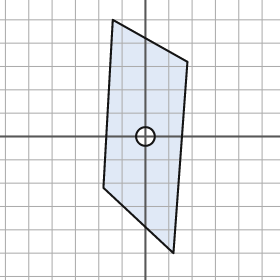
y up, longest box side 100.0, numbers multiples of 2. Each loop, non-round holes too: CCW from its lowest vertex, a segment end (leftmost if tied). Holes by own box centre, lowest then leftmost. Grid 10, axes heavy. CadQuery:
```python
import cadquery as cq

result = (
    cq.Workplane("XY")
    .moveTo(12.0, -50.0)
    .lineTo(18.0, 32.0)
    .lineTo(-14.0, 50.0)
    .lineTo(-18.0, -22.0)
    .close()
    .moveTo(0.0, 0.0)
    .circle(4.0)
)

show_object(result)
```